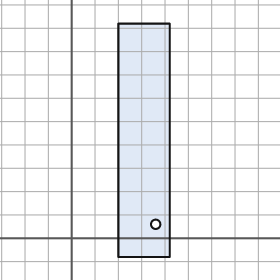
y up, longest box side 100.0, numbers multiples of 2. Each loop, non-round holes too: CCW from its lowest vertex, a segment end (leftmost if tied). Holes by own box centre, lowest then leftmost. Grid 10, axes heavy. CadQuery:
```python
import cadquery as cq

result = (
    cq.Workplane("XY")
    .moveTo(20.0, -8.0)
    .lineTo(42.0, -8.0)
    .lineTo(42.0, 92.0)
    .lineTo(20.0, 92.0)
    .close()
    .moveTo(36.0, 6.0)
    .circle(2.0)
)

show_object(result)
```